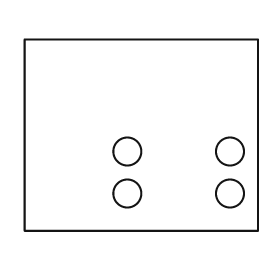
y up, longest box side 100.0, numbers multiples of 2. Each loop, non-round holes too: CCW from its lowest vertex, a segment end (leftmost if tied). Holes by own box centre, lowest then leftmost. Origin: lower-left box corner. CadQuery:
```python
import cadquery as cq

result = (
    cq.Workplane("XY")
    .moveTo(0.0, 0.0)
    .lineTo(100.0, 0.0)
    .lineTo(100.0, 82.0)
    .lineTo(0.0, 82.0)
    .close()
    .moveTo(44.0, 16.0)
    .circle(6.0)
    .moveTo(88.0, 16.0)
    .circle(6.0)
    .moveTo(44.0, 34.0)
    .circle(6.0)
    .moveTo(88.0, 34.0)
    .circle(6.0)
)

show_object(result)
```